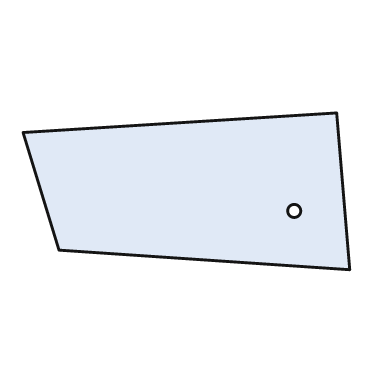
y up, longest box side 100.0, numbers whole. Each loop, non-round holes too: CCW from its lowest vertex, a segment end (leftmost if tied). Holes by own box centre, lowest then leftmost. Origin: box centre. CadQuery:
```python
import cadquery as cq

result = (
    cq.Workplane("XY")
    .moveTo(50.0, -24.0)
    .lineTo(46.0, 24.0)
    .lineTo(-50.0, 18.0)
    .lineTo(-39.0, -18.0)
    .close()
    .moveTo(33.0, -6.0)
    .circle(2.0)
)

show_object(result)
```